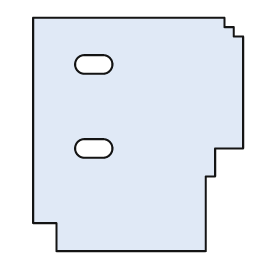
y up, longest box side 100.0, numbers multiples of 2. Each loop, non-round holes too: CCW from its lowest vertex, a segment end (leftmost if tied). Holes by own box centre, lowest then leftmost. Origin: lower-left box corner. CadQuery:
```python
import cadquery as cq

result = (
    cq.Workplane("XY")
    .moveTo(10.0, 0.0)
    .lineTo(74.0, 0.0)
    .lineTo(74.0, 32.0)
    .lineTo(78.0, 32.0)
    .lineTo(78.0, 44.0)
    .lineTo(90.0, 44.0)
    .lineTo(90.0, 92.0)
    .lineTo(86.0, 92.0)
    .lineTo(86.0, 96.0)
    .lineTo(82.0, 96.0)
    .lineTo(82.0, 100.0)
    .lineTo(0.0, 100.0)
    .lineTo(0.0, 12.0)
    .lineTo(10.0, 12.0)
    .close()
    .moveTo(22.0, 40.0)
    .lineTo(30.0, 40.0)
    .threePointArc((34.0, 44.0), (30.0, 48.0))
    .lineTo(22.0, 48.0)
    .threePointArc((18.0, 44.0), (22.0, 40.0))
    .close()
    .moveTo(22.0, 76.0)
    .lineTo(30.0, 76.0)
    .threePointArc((34.0, 80.0), (30.0, 84.0))
    .lineTo(22.0, 84.0)
    .threePointArc((18.0, 80.0), (22.0, 76.0))
    .close()
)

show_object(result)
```